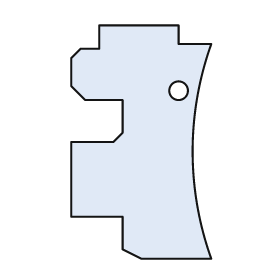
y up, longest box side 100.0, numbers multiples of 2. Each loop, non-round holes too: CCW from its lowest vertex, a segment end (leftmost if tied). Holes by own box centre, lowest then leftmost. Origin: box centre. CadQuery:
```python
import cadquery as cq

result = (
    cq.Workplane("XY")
    .moveTo(0.0, -50.0)
    .lineTo(30.0, -50.0)
    .threePointArc((22.0, -4.0), (30.0, 42.0))
    .lineTo(16.0, 42.0)
    .lineTo(16.0, 50.0)
    .lineTo(-18.0, 50.0)
    .lineTo(-18.0, 40.0)
    .lineTo(-26.0, 40.0)
    .lineTo(-30.0, 36.0)
    .lineTo(-30.0, 24.0)
    .lineTo(-24.0, 18.0)
    .lineTo(-8.0, 18.0)
    .lineTo(-8.0, 4.0)
    .lineTo(-12.0, 0.0)
    .lineTo(-30.0, 0.0)
    .lineTo(-30.0, -32.0)
    .lineTo(-8.0, -32.0)
    .lineTo(-8.0, -46.0)
    .close()
    .moveTo(16.0, 22.0)
    .circle(4.0)
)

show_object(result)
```